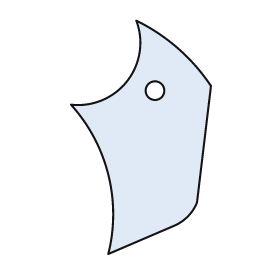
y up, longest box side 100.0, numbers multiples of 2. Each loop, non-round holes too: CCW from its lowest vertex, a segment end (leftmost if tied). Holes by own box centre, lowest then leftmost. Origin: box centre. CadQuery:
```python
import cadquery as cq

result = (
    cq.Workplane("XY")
    .moveTo(-14.0, -50.0)
    .lineTo(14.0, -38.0)
    .threePointArc((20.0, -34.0), (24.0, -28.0))
    .lineTo(30.0, 22.0)
    .threePointArc((16.0, 38.0), (-2.0, 50.0))
    .threePointArc((-6.0, 24.0), (-30.0, 14.0))
    .threePointArc((-14.0, -16.0), (-14.0, -50.0))
    .close()
    .moveTo(6.0, 20.0)
    .circle(4.0)
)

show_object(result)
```